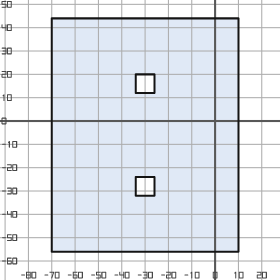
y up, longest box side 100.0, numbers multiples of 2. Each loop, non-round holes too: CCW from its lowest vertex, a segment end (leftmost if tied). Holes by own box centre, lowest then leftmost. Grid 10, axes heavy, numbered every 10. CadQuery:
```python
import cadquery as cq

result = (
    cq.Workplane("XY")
    .moveTo(-70.0, -56.0)
    .lineTo(10.0, -56.0)
    .lineTo(10.0, 44.0)
    .lineTo(-70.0, 44.0)
    .close()
    .moveTo(-34.0, -32.0)
    .lineTo(-26.0, -32.0)
    .lineTo(-26.0, -24.0)
    .lineTo(-34.0, -24.0)
    .close()
    .moveTo(-34.0, 12.0)
    .lineTo(-26.0, 12.0)
    .lineTo(-26.0, 20.0)
    .lineTo(-34.0, 20.0)
    .close()
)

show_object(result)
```